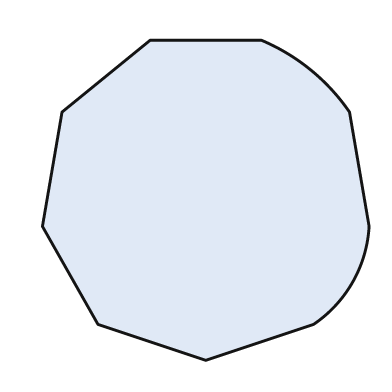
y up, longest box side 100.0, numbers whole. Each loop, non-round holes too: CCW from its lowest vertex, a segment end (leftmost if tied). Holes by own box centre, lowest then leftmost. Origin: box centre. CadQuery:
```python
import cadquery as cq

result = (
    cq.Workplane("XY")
    .moveTo(0.0, -49.0)
    .lineTo(33.0, -38.0)
    .threePointArc((45.0, -25.0), (50.0, -8.0))
    .lineTo(44.0, 27.0)
    .threePointArc((32.0, 40.0), (17.0, 49.0))
    .lineTo(-17.0, 49.0)
    .lineTo(-44.0, 27.0)
    .lineTo(-50.0, -8.0)
    .lineTo(-33.0, -38.0)
    .close()
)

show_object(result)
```